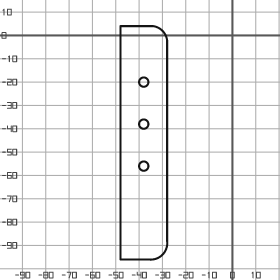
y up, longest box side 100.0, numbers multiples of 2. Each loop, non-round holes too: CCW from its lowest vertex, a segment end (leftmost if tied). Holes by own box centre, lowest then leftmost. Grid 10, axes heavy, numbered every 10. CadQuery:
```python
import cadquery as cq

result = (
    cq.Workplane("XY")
    .moveTo(-48.0, -96.0)
    .lineTo(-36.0, -96.0)
    .threePointArc((-30.0, -94.0), (-28.0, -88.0))
    .lineTo(-28.0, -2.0)
    .threePointArc((-30.0, 2.0), (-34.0, 4.0))
    .lineTo(-48.0, 4.0)
    .close()
    .moveTo(-38.0, -56.0)
    .circle(2.0)
    .moveTo(-38.0, -38.0)
    .circle(2.0)
    .moveTo(-38.0, -20.0)
    .circle(2.0)
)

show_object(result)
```